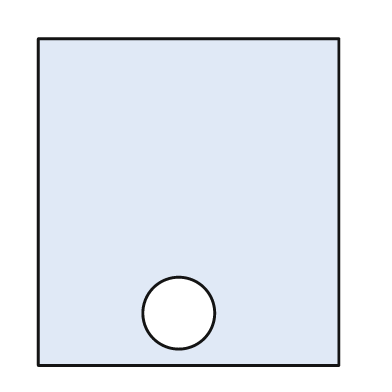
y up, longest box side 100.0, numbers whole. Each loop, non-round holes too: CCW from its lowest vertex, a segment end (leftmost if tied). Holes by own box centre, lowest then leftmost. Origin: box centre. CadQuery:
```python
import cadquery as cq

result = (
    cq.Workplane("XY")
    .moveTo(-46.0, -50.0)
    .lineTo(46.0, -50.0)
    .lineTo(46.0, 50.0)
    .lineTo(-46.0, 50.0)
    .close()
    .moveTo(-3.0, -34.0)
    .circle(11.0)
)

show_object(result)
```